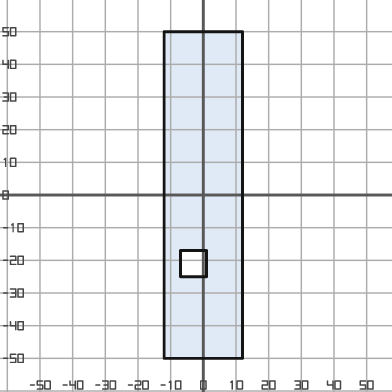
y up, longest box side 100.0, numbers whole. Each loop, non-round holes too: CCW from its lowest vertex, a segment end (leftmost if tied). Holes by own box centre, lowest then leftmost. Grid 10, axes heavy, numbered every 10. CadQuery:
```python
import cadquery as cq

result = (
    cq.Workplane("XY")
    .moveTo(-12.0, -50.0)
    .lineTo(12.0, -50.0)
    .lineTo(12.0, 50.0)
    .lineTo(-12.0, 50.0)
    .close()
    .moveTo(-7.0, -25.0)
    .lineTo(1.0, -25.0)
    .lineTo(1.0, -17.0)
    .lineTo(-7.0, -17.0)
    .close()
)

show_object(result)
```